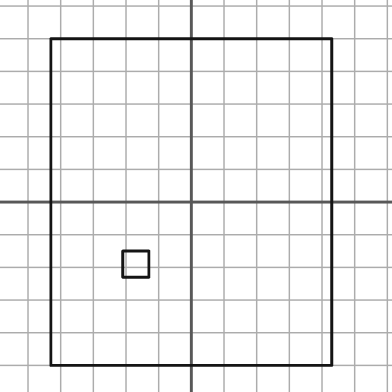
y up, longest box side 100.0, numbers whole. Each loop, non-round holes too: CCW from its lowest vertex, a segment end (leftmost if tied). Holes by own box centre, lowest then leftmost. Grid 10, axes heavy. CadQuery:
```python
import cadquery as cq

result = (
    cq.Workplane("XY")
    .moveTo(-43.0, -50.0)
    .lineTo(43.0, -50.0)
    .lineTo(43.0, 50.0)
    .lineTo(-43.0, 50.0)
    .close()
    .moveTo(-21.0, -23.0)
    .lineTo(-13.0, -23.0)
    .lineTo(-13.0, -15.0)
    .lineTo(-21.0, -15.0)
    .close()
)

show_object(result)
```